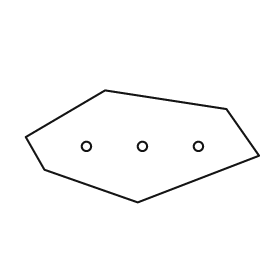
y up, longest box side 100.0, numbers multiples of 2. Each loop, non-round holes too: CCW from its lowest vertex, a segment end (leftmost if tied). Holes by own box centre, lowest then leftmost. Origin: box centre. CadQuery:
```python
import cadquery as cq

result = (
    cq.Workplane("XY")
    .moveTo(-2.0, -24.0)
    .lineTo(50.0, -4.0)
    .lineTo(36.0, 16.0)
    .lineTo(-16.0, 24.0)
    .lineTo(-50.0, 4.0)
    .lineTo(-42.0, -10.0)
    .close()
    .moveTo(-24.0, 0.0)
    .circle(2.0)
    .moveTo(0.0, 0.0)
    .circle(2.0)
    .moveTo(24.0, 0.0)
    .circle(2.0)
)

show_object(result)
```